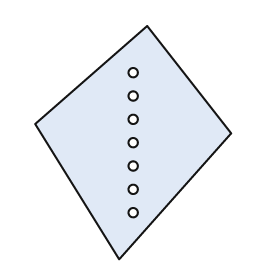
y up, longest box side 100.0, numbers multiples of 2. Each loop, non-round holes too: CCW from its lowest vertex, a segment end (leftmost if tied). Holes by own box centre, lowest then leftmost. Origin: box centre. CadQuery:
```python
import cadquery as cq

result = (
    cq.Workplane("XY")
    .moveTo(-6.0, -50.0)
    .lineTo(42.0, 4.0)
    .lineTo(6.0, 50.0)
    .lineTo(-42.0, 8.0)
    .close()
    .moveTo(0.0, -30.0)
    .circle(2.0)
    .moveTo(0.0, -20.0)
    .circle(2.0)
    .moveTo(0.0, -10.0)
    .circle(2.0)
    .moveTo(0.0, 0.0)
    .circle(2.0)
    .moveTo(0.0, 10.0)
    .circle(2.0)
    .moveTo(0.0, 20.0)
    .circle(2.0)
    .moveTo(0.0, 30.0)
    .circle(2.0)
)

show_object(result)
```